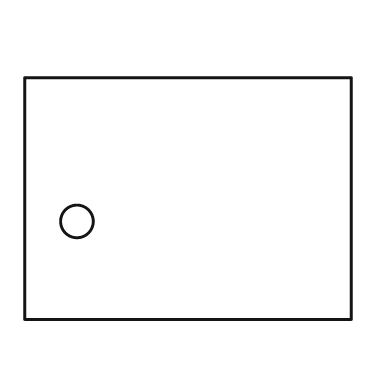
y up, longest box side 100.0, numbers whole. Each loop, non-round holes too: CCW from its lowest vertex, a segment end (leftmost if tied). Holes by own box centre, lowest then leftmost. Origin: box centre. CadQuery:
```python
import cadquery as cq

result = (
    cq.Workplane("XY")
    .moveTo(-50.0, -37.0)
    .lineTo(50.0, -37.0)
    .lineTo(50.0, 37.0)
    .lineTo(-50.0, 37.0)
    .close()
    .moveTo(-34.0, -7.0)
    .circle(5.0)
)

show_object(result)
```